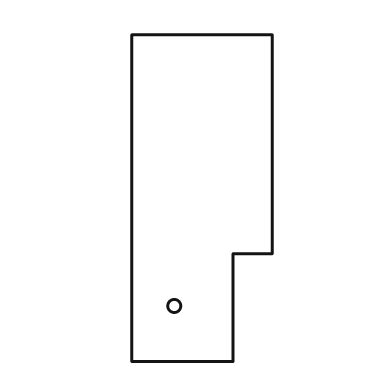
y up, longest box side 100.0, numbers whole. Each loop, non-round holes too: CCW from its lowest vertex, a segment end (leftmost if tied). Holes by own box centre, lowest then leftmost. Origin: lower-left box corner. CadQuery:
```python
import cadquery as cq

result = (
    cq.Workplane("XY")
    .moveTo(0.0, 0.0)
    .lineTo(31.0, 0.0)
    .lineTo(31.0, 33.0)
    .lineTo(43.0, 33.0)
    .lineTo(43.0, 100.0)
    .lineTo(0.0, 100.0)
    .close()
    .moveTo(13.0, 17.0)
    .circle(2.0)
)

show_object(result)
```